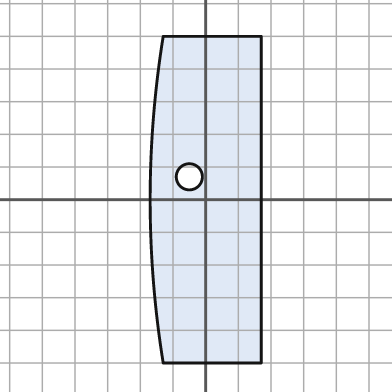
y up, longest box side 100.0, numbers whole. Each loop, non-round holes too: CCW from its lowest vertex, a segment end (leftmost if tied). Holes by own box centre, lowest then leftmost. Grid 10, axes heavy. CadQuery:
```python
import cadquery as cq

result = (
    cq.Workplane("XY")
    .moveTo(-13.0, -50.0)
    .lineTo(17.0, -50.0)
    .lineTo(17.0, 50.0)
    .lineTo(-13.0, 50.0)
    .threePointArc((-17.0, 0.0), (-13.0, -50.0))
    .close()
    .moveTo(-5.0, 7.0)
    .circle(4.0)
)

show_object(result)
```